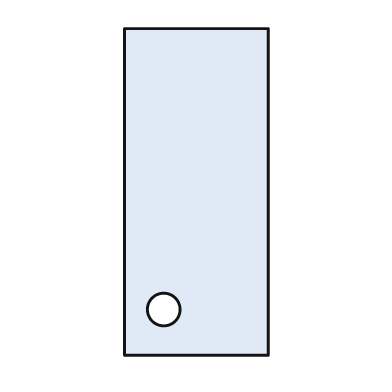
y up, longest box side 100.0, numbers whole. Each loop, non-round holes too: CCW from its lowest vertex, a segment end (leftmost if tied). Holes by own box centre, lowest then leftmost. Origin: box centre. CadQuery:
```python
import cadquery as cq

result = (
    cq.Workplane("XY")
    .moveTo(-22.0, -50.0)
    .lineTo(22.0, -50.0)
    .lineTo(22.0, 50.0)
    .lineTo(-22.0, 50.0)
    .close()
    .moveTo(-10.0, -36.0)
    .circle(5.0)
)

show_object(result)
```